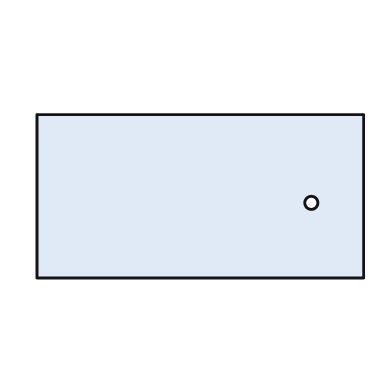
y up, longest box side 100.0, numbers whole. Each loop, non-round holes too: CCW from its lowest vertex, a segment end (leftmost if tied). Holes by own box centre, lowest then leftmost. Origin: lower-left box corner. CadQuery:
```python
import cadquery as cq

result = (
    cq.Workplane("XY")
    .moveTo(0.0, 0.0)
    .lineTo(100.0, 0.0)
    .lineTo(100.0, 50.0)
    .lineTo(0.0, 50.0)
    .close()
    .moveTo(84.0, 23.0)
    .circle(2.0)
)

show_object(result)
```